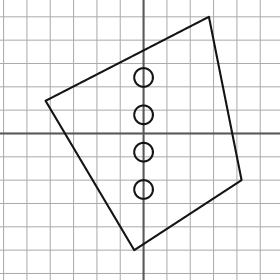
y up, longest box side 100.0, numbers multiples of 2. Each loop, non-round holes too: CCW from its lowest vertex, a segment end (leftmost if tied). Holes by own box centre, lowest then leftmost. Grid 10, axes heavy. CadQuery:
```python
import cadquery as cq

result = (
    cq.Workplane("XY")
    .moveTo(-4.0, -50.0)
    .lineTo(42.0, -20.0)
    .lineTo(28.0, 50.0)
    .lineTo(-42.0, 14.0)
    .close()
    .moveTo(0.0, -24.0)
    .circle(4.0)
    .moveTo(0.0, -8.0)
    .circle(4.0)
    .moveTo(0.0, 8.0)
    .circle(4.0)
    .moveTo(0.0, 24.0)
    .circle(4.0)
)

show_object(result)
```